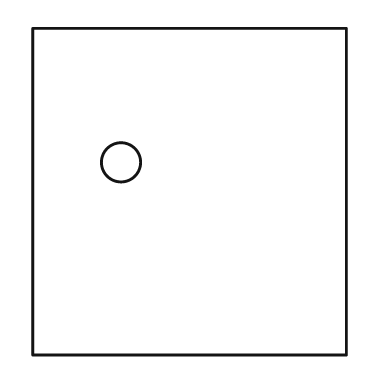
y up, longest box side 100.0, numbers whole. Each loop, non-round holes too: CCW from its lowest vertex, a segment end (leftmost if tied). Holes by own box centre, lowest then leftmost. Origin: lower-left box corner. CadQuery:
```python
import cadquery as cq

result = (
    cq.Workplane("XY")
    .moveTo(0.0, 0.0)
    .lineTo(96.0, 0.0)
    .lineTo(96.0, 100.0)
    .lineTo(0.0, 100.0)
    .close()
    .moveTo(27.0, 59.0)
    .circle(6.0)
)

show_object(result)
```